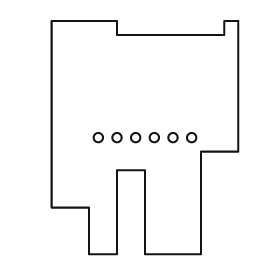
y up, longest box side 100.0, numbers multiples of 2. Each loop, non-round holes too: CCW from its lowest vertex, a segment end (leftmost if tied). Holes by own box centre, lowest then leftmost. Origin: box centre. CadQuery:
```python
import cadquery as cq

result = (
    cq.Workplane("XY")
    .moveTo(-24.0, -50.0)
    .lineTo(-12.0, -50.0)
    .lineTo(-12.0, -14.0)
    .lineTo(0.0, -14.0)
    .lineTo(0.0, -50.0)
    .lineTo(24.0, -50.0)
    .lineTo(24.0, -6.0)
    .lineTo(40.0, -6.0)
    .lineTo(40.0, 50.0)
    .lineTo(34.0, 50.0)
    .lineTo(34.0, 44.0)
    .lineTo(-12.0, 44.0)
    .lineTo(-12.0, 50.0)
    .lineTo(-40.0, 50.0)
    .lineTo(-40.0, -30.0)
    .lineTo(-24.0, -30.0)
    .close()
    .moveTo(-20.0, 0.0)
    .circle(2.0)
    .moveTo(-12.0, 0.0)
    .circle(2.0)
    .moveTo(-4.0, 0.0)
    .circle(2.0)
    .moveTo(4.0, 0.0)
    .circle(2.0)
    .moveTo(12.0, 0.0)
    .circle(2.0)
    .moveTo(20.0, 0.0)
    .circle(2.0)
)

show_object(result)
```